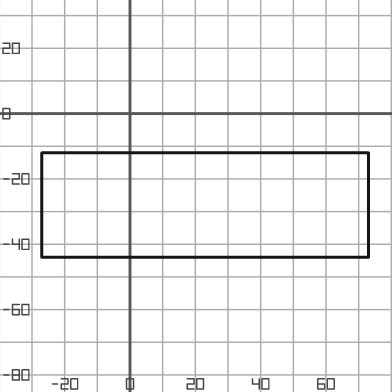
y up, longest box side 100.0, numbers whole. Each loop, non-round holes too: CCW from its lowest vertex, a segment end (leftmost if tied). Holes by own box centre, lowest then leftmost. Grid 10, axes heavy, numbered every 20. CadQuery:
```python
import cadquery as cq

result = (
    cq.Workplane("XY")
    .moveTo(-27.0, -44.0)
    .lineTo(73.0, -44.0)
    .lineTo(73.0, -12.0)
    .lineTo(-27.0, -12.0)
    .close()
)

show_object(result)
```